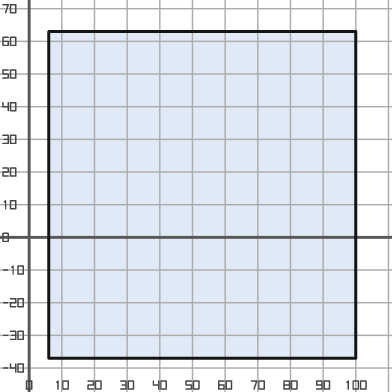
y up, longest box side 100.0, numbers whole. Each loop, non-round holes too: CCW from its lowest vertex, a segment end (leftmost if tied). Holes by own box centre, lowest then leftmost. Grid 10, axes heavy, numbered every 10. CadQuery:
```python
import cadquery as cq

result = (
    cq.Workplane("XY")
    .moveTo(6.0, -37.0)
    .lineTo(100.0, -37.0)
    .lineTo(100.0, 63.0)
    .lineTo(6.0, 63.0)
    .close()
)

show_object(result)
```